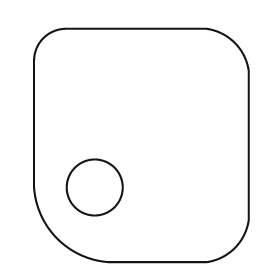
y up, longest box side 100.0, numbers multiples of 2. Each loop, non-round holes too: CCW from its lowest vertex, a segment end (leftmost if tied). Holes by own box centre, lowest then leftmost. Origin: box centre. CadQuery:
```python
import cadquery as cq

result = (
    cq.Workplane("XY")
    .moveTo(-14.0, -50.0)
    .lineTo(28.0, -50.0)
    .threePointArc((40.0, -44.0), (46.0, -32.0))
    .lineTo(46.0, 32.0)
    .threePointArc((40.0, 44.0), (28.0, 50.0))
    .lineTo(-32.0, 50.0)
    .threePointArc((-42.0, 46.0), (-46.0, 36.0))
    .lineTo(-46.0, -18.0)
    .threePointArc((-36.0, -40.0), (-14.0, -50.0))
    .close()
    .moveTo(-20.0, -18.0)
    .circle(12.0)
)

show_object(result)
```